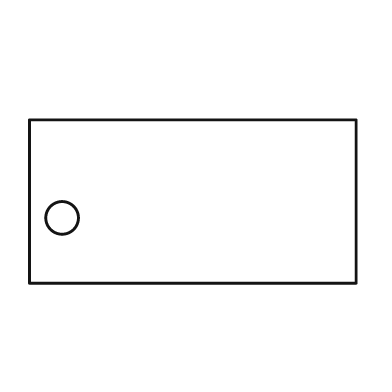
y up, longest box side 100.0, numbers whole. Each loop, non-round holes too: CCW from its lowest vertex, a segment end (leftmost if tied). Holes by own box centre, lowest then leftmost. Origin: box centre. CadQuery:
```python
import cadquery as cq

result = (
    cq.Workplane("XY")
    .moveTo(-50.0, -25.0)
    .lineTo(50.0, -25.0)
    .lineTo(50.0, 25.0)
    .lineTo(-50.0, 25.0)
    .close()
    .moveTo(-40.0, -5.0)
    .circle(5.0)
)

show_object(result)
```